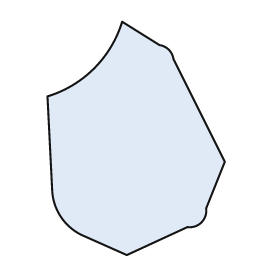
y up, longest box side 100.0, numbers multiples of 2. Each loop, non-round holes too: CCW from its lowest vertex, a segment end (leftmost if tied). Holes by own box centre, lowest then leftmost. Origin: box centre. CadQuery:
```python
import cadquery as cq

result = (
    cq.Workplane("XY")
    .moveTo(-4.0, -50.0)
    .lineTo(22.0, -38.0)
    .threePointArc((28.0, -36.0), (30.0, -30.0))
    .lineTo(38.0, -10.0)
    .lineTo(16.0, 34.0)
    .threePointArc((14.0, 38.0), (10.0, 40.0))
    .lineTo(-6.0, 50.0)
    .threePointArc((-18.0, 30.0), (-38.0, 18.0))
    .lineTo(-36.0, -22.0)
    .threePointArc((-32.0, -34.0), (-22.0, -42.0))
    .close()
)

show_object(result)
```